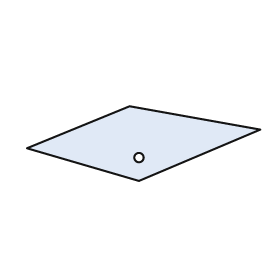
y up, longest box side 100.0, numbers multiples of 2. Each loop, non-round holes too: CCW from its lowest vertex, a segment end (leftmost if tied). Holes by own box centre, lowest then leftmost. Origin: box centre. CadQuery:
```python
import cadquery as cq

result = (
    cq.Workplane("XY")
    .moveTo(-2.0, -16.0)
    .lineTo(50.0, 6.0)
    .lineTo(-6.0, 16.0)
    .lineTo(-50.0, -2.0)
    .close()
    .moveTo(-2.0, -6.0)
    .circle(2.0)
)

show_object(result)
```